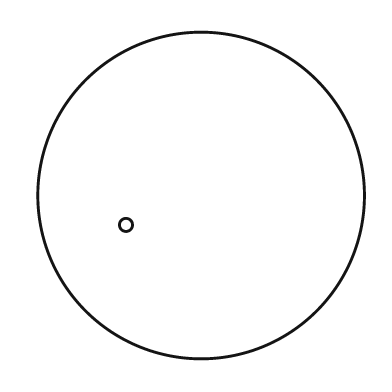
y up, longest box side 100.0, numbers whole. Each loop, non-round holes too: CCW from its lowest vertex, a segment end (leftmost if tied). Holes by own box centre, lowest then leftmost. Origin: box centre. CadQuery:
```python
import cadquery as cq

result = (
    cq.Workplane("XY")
    .moveTo(0.0, 0.0)
    .circle(50.0)
    .moveTo(-23.0, -9.0)
    .circle(2.0)
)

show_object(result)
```